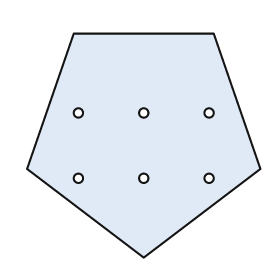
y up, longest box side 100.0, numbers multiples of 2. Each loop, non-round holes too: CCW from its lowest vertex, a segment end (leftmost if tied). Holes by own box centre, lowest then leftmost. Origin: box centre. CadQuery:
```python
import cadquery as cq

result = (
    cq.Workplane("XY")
    .moveTo(0.0, -48.0)
    .lineTo(50.0, -10.0)
    .lineTo(30.0, 48.0)
    .lineTo(-30.0, 48.0)
    .lineTo(-50.0, -10.0)
    .close()
    .moveTo(-28.0, -14.0)
    .circle(2.0)
    .moveTo(0.0, -14.0)
    .circle(2.0)
    .moveTo(28.0, -14.0)
    .circle(2.0)
    .moveTo(-28.0, 14.0)
    .circle(2.0)
    .moveTo(0.0, 14.0)
    .circle(2.0)
    .moveTo(28.0, 14.0)
    .circle(2.0)
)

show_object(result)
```